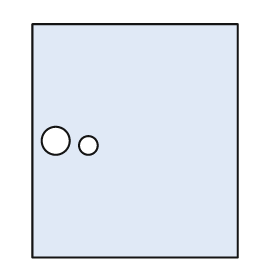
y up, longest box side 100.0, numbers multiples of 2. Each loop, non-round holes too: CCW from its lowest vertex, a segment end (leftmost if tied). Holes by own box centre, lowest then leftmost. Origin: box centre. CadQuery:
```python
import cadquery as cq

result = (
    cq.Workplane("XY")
    .moveTo(-44.0, -50.0)
    .lineTo(44.0, -50.0)
    .lineTo(44.0, 50.0)
    .lineTo(-44.0, 50.0)
    .close()
    .moveTo(-20.0, -2.0)
    .circle(4.0)
    .moveTo(-34.0, 0.0)
    .circle(6.0)
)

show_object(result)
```